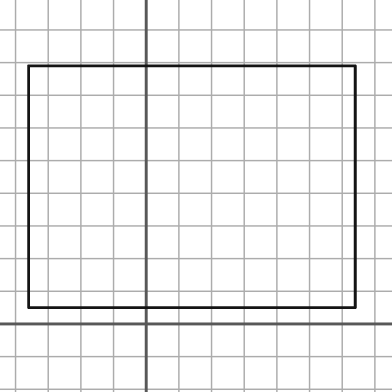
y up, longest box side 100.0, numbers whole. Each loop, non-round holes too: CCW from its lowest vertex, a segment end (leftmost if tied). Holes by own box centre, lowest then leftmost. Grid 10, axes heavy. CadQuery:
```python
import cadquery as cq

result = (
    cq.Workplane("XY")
    .moveTo(-36.0, 5.0)
    .lineTo(64.0, 5.0)
    .lineTo(64.0, 79.0)
    .lineTo(-36.0, 79.0)
    .close()
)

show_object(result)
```